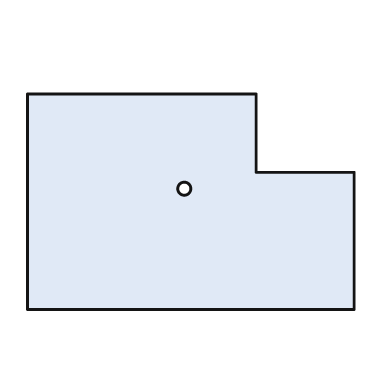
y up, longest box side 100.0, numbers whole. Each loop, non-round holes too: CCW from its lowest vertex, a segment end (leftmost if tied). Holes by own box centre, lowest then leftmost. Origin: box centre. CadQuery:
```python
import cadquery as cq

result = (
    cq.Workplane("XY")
    .moveTo(-50.0, -33.0)
    .lineTo(50.0, -33.0)
    .lineTo(50.0, 9.0)
    .lineTo(20.0, 9.0)
    .lineTo(20.0, 33.0)
    .lineTo(-50.0, 33.0)
    .close()
    .moveTo(-2.0, 4.0)
    .circle(2.0)
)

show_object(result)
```